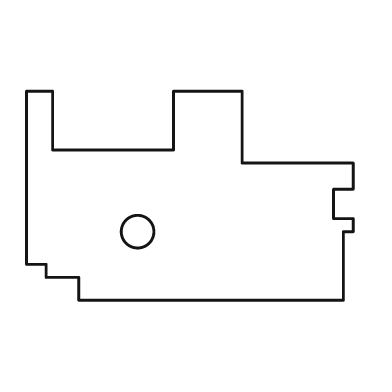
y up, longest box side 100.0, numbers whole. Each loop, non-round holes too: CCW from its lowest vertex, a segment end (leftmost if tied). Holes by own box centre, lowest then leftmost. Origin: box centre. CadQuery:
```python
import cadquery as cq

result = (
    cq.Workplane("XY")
    .moveTo(-34.0, -32.0)
    .lineTo(47.0, -32.0)
    .lineTo(47.0, -11.0)
    .lineTo(50.0, -11.0)
    .lineTo(50.0, -7.0)
    .lineTo(44.0, -7.0)
    .lineTo(44.0, 2.0)
    .lineTo(50.0, 2.0)
    .lineTo(50.0, 10.0)
    .lineTo(16.0, 10.0)
    .lineTo(16.0, 32.0)
    .lineTo(-5.0, 32.0)
    .lineTo(-5.0, 14.0)
    .lineTo(-42.0, 14.0)
    .lineTo(-42.0, 32.0)
    .lineTo(-50.0, 32.0)
    .lineTo(-50.0, -21.0)
    .lineTo(-44.0, -21.0)
    .lineTo(-44.0, -25.0)
    .lineTo(-34.0, -25.0)
    .close()
    .moveTo(-16.0, -11.0)
    .circle(5.0)
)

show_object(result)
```